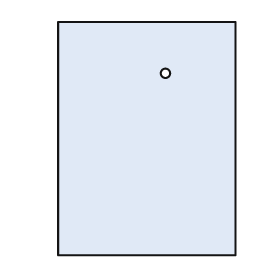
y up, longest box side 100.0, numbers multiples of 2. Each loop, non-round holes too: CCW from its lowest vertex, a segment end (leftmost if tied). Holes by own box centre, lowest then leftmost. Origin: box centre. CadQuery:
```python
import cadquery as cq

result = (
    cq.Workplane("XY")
    .moveTo(-38.0, -50.0)
    .lineTo(38.0, -50.0)
    .lineTo(38.0, 50.0)
    .lineTo(-38.0, 50.0)
    .close()
    .moveTo(8.0, 28.0)
    .circle(2.0)
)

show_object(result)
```